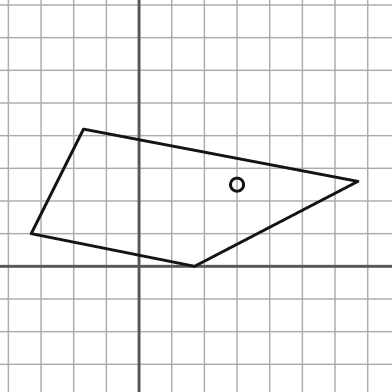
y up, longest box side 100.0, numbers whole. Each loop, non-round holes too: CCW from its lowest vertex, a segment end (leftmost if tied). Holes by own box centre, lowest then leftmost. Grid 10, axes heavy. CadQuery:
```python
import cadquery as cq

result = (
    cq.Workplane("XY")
    .moveTo(17.0, 0.0)
    .lineTo(67.0, 26.0)
    .lineTo(-17.0, 42.0)
    .lineTo(-33.0, 10.0)
    .close()
    .moveTo(30.0, 25.0)
    .circle(2.0)
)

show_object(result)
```